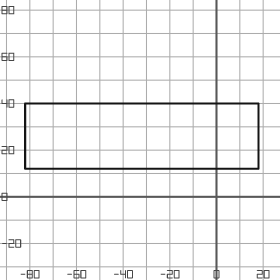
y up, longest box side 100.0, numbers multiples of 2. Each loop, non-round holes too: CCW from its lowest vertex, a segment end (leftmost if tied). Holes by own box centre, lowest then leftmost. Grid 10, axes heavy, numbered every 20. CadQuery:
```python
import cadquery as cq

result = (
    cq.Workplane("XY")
    .moveTo(-82.0, 12.0)
    .lineTo(18.0, 12.0)
    .lineTo(18.0, 40.0)
    .lineTo(-82.0, 40.0)
    .close()
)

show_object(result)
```